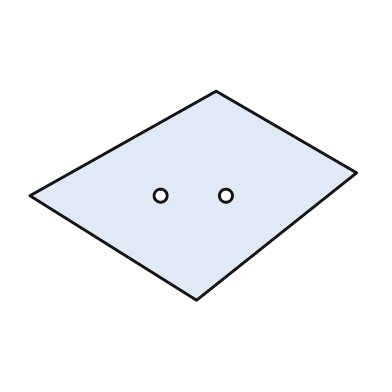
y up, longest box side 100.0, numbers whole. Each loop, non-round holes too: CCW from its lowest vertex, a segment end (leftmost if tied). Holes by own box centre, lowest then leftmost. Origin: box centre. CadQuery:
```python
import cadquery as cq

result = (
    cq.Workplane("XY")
    .moveTo(1.0, -32.0)
    .lineTo(50.0, 7.0)
    .lineTo(7.0, 32.0)
    .lineTo(-50.0, 0.0)
    .close()
    .moveTo(-10.0, 0.0)
    .circle(2.0)
    .moveTo(10.0, 0.0)
    .circle(2.0)
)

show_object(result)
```